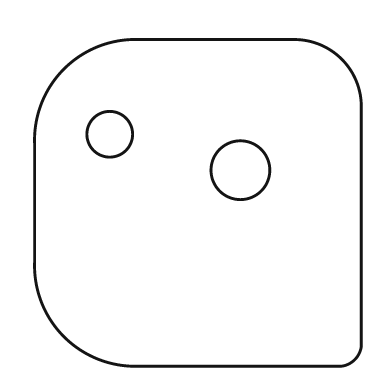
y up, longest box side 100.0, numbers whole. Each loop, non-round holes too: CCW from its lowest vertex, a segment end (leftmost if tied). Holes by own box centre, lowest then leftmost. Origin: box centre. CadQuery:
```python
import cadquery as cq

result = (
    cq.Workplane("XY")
    .moveTo(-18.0, -50.0)
    .lineTo(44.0, -50.0)
    .threePointArc((48.0, -48.0), (50.0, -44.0))
    .lineTo(50.0, 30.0)
    .threePointArc((44.0, 44.0), (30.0, 50.0))
    .lineTo(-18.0, 50.0)
    .threePointArc((-41.0, 41.0), (-50.0, 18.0))
    .lineTo(-50.0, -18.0)
    .threePointArc((-41.0, -41.0), (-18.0, -50.0))
    .close()
    .moveTo(13.0, 10.0)
    .circle(9.0)
    .moveTo(-27.0, 21.0)
    .circle(7.0)
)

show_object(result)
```